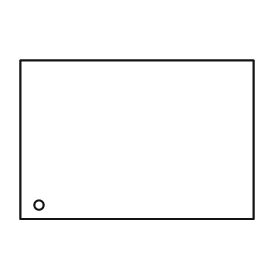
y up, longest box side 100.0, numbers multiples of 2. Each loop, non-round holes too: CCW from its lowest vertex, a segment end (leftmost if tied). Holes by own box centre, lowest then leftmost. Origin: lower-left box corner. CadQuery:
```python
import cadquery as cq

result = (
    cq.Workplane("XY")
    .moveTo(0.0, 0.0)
    .lineTo(100.0, 0.0)
    .lineTo(100.0, 68.0)
    .lineTo(0.0, 68.0)
    .close()
    .moveTo(8.0, 6.0)
    .circle(2.0)
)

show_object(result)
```